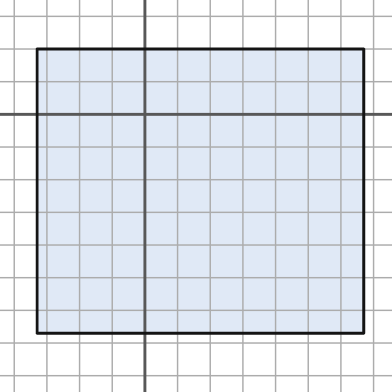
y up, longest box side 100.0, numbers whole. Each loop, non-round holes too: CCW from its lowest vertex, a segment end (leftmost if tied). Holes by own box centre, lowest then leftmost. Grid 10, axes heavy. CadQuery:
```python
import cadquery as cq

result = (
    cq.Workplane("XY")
    .moveTo(-33.0, -67.0)
    .lineTo(67.0, -67.0)
    .lineTo(67.0, 20.0)
    .lineTo(-33.0, 20.0)
    .close()
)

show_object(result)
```